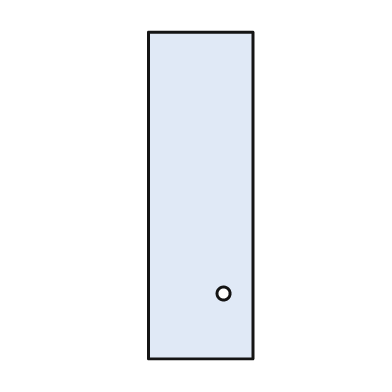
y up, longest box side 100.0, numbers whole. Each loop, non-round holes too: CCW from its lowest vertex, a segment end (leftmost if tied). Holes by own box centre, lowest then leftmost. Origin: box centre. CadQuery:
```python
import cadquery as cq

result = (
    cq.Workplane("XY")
    .moveTo(-16.0, -50.0)
    .lineTo(16.0, -50.0)
    .lineTo(16.0, 50.0)
    .lineTo(-16.0, 50.0)
    .close()
    .moveTo(7.0, -30.0)
    .circle(2.0)
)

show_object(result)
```